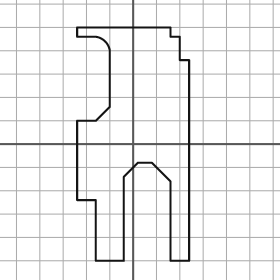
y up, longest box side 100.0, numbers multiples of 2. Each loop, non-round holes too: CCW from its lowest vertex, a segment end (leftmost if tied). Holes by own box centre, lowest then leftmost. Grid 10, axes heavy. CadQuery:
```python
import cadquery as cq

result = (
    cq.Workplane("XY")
    .moveTo(-16.0, -50.0)
    .lineTo(-4.0, -50.0)
    .lineTo(-4.0, -14.0)
    .lineTo(2.0, -8.0)
    .lineTo(8.0, -8.0)
    .lineTo(16.0, -16.0)
    .lineTo(16.0, -50.0)
    .lineTo(24.0, -50.0)
    .lineTo(24.0, 36.0)
    .lineTo(20.0, 36.0)
    .lineTo(20.0, 46.0)
    .lineTo(16.0, 46.0)
    .lineTo(16.0, 50.0)
    .lineTo(-24.0, 50.0)
    .lineTo(-24.0, 46.0)
    .lineTo(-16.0, 46.0)
    .threePointArc((-12.0, 44.0), (-10.0, 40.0))
    .lineTo(-10.0, 16.0)
    .lineTo(-16.0, 10.0)
    .lineTo(-24.0, 10.0)
    .lineTo(-24.0, -24.0)
    .lineTo(-16.0, -24.0)
    .close()
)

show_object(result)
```